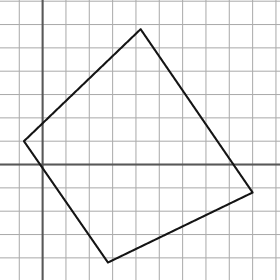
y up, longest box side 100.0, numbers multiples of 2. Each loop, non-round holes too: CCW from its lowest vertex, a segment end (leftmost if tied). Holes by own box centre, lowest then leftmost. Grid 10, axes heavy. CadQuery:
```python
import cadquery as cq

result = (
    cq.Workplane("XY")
    .moveTo(28.0, -42.0)
    .lineTo(90.0, -12.0)
    .lineTo(42.0, 58.0)
    .lineTo(-8.0, 10.0)
    .close()
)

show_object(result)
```